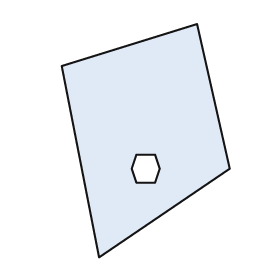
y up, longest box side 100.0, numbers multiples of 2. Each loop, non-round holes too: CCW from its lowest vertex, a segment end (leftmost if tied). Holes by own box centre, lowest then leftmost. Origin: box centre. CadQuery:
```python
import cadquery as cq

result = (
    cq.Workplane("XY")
    .moveTo(-20.0, -50.0)
    .lineTo(36.0, -12.0)
    .lineTo(22.0, 50.0)
    .lineTo(-36.0, 32.0)
    .close()
    .moveTo(-4.0, -18.0)
    .lineTo(4.0, -18.0)
    .lineTo(6.0, -12.0)
    .lineTo(4.0, -6.0)
    .lineTo(-4.0, -6.0)
    .lineTo(-6.0, -12.0)
    .close()
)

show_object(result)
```